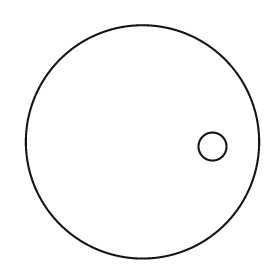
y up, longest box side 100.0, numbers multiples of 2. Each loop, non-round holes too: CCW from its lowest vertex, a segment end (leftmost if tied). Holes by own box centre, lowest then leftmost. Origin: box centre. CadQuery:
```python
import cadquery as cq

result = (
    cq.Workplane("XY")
    .moveTo(0.0, 0.0)
    .circle(50.0)
    .moveTo(30.0, -2.0)
    .circle(6.0)
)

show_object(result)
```